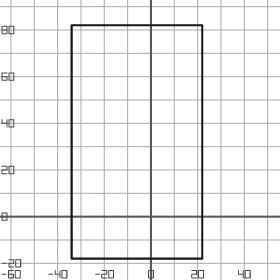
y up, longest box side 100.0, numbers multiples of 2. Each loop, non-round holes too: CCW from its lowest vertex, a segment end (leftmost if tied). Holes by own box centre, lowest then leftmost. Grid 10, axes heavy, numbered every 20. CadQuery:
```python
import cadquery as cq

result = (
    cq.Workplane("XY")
    .moveTo(-34.0, -18.0)
    .lineTo(22.0, -18.0)
    .lineTo(22.0, 82.0)
    .lineTo(-34.0, 82.0)
    .close()
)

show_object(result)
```